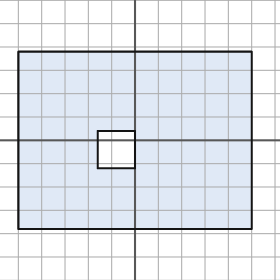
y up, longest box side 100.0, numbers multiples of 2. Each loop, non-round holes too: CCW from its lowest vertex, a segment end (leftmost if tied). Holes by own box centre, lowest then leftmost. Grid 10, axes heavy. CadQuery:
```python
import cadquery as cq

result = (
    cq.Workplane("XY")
    .moveTo(-50.0, -38.0)
    .lineTo(50.0, -38.0)
    .lineTo(50.0, 38.0)
    .lineTo(-50.0, 38.0)
    .close()
    .moveTo(-16.0, -12.0)
    .lineTo(0.0, -12.0)
    .lineTo(0.0, 4.0)
    .lineTo(-16.0, 4.0)
    .close()
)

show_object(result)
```